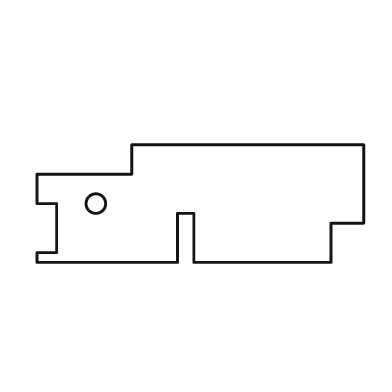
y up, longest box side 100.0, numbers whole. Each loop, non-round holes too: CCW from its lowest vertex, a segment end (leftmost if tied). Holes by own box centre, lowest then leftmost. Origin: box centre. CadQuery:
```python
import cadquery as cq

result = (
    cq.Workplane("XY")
    .moveTo(-50.0, -18.0)
    .lineTo(-7.0, -18.0)
    .lineTo(-7.0, -3.0)
    .lineTo(-2.0, -3.0)
    .lineTo(-2.0, -18.0)
    .lineTo(40.0, -18.0)
    .lineTo(40.0, -6.0)
    .lineTo(50.0, -6.0)
    .lineTo(50.0, 18.0)
    .lineTo(-21.0, 18.0)
    .lineTo(-21.0, 9.0)
    .lineTo(-50.0, 9.0)
    .lineTo(-50.0, 0.0)
    .lineTo(-44.0, 0.0)
    .lineTo(-44.0, -15.0)
    .lineTo(-50.0, -15.0)
    .close()
    .moveTo(-32.0, 0.0)
    .circle(3.0)
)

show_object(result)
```